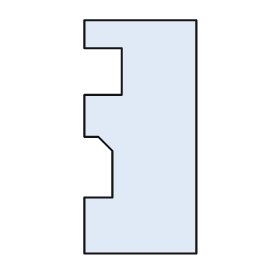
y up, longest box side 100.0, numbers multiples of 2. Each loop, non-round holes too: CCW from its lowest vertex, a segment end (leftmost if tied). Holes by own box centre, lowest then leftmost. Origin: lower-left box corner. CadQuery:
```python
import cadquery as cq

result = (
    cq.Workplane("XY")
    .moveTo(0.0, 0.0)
    .lineTo(48.0, 0.0)
    .lineTo(48.0, 100.0)
    .lineTo(0.0, 100.0)
    .lineTo(0.0, 88.0)
    .lineTo(16.0, 88.0)
    .lineTo(16.0, 68.0)
    .lineTo(0.0, 68.0)
    .lineTo(0.0, 50.0)
    .lineTo(6.0, 50.0)
    .lineTo(12.0, 44.0)
    .lineTo(12.0, 24.0)
    .lineTo(0.0, 24.0)
    .close()
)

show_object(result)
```